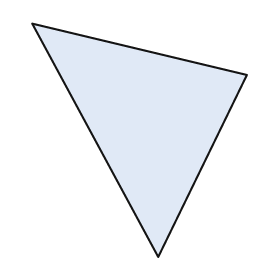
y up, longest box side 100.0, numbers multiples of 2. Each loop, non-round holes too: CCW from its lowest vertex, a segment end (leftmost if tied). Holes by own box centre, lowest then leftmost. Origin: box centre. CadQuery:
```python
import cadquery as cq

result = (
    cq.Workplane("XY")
    .moveTo(8.0, -50.0)
    .lineTo(46.0, 28.0)
    .lineTo(-46.0, 50.0)
    .close()
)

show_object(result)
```